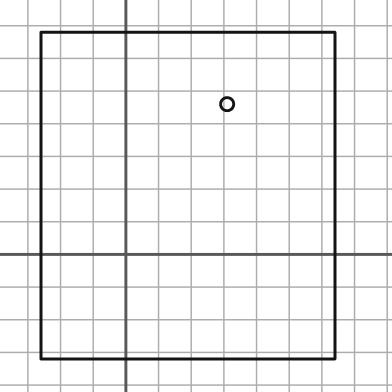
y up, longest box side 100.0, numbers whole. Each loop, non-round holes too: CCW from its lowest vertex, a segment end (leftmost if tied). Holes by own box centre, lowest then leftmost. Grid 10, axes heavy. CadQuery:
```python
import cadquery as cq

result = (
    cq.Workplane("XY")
    .moveTo(-26.0, -32.0)
    .lineTo(64.0, -32.0)
    .lineTo(64.0, 68.0)
    .lineTo(-26.0, 68.0)
    .close()
    .moveTo(31.0, 46.0)
    .circle(2.0)
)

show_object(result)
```